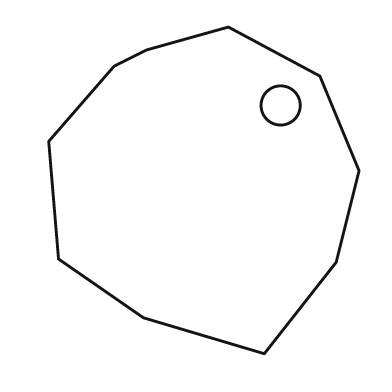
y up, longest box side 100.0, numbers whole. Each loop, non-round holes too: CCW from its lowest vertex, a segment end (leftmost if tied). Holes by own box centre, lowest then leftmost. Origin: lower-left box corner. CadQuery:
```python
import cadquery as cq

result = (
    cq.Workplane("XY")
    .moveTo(66.0, 0.0)
    .lineTo(88.0, 28.0)
    .lineTo(95.0, 56.0)
    .lineTo(83.0, 85.0)
    .lineTo(55.0, 100.0)
    .lineTo(30.0, 93.0)
    .lineTo(20.0, 88.0)
    .lineTo(0.0, 65.0)
    .lineTo(3.0, 29.0)
    .lineTo(29.0, 11.0)
    .close()
    .moveTo(71.0, 76.0)
    .circle(6.0)
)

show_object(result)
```